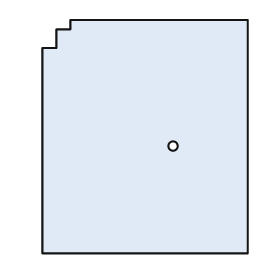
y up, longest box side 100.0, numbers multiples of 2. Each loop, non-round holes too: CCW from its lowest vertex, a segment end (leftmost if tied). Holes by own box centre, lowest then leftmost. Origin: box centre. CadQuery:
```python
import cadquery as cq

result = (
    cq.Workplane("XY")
    .moveTo(-44.0, -50.0)
    .lineTo(44.0, -50.0)
    .lineTo(44.0, 50.0)
    .lineTo(-32.0, 50.0)
    .lineTo(-32.0, 46.0)
    .lineTo(-38.0, 46.0)
    .lineTo(-38.0, 38.0)
    .lineTo(-44.0, 38.0)
    .close()
    .moveTo(12.0, -4.0)
    .circle(2.0)
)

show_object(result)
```